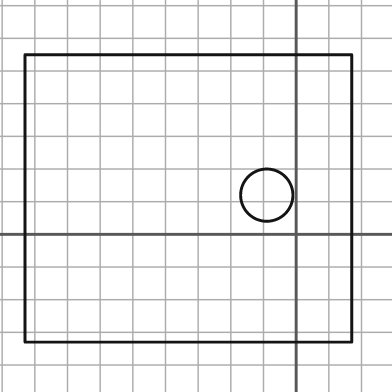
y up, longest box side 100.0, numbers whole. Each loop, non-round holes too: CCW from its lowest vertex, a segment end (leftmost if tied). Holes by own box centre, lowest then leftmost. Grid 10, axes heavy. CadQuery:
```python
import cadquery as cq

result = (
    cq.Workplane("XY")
    .moveTo(-83.0, -33.0)
    .lineTo(17.0, -33.0)
    .lineTo(17.0, 55.0)
    .lineTo(-83.0, 55.0)
    .close()
    .moveTo(-9.0, 12.0)
    .circle(8.0)
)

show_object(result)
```